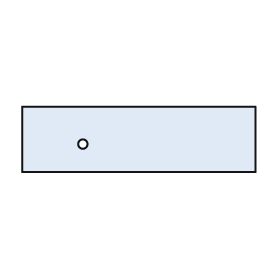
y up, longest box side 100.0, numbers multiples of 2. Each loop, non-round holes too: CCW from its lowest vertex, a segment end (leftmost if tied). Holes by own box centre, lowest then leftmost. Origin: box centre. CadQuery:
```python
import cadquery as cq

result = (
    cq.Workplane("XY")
    .moveTo(-50.0, -14.0)
    .lineTo(50.0, -14.0)
    .lineTo(50.0, 14.0)
    .lineTo(-50.0, 14.0)
    .close()
    .moveTo(-24.0, -2.0)
    .circle(2.0)
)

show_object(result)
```